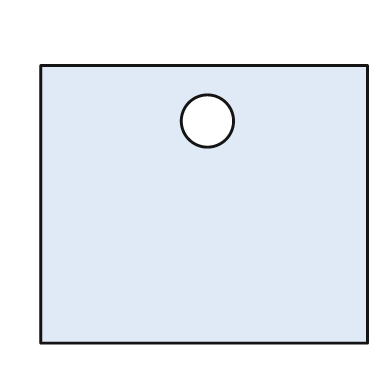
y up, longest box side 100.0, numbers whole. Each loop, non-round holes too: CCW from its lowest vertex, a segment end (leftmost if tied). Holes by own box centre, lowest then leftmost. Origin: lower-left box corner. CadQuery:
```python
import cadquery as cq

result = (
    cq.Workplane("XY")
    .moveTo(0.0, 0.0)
    .lineTo(100.0, 0.0)
    .lineTo(100.0, 85.0)
    .lineTo(0.0, 85.0)
    .close()
    .moveTo(51.0, 68.0)
    .circle(8.0)
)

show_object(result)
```